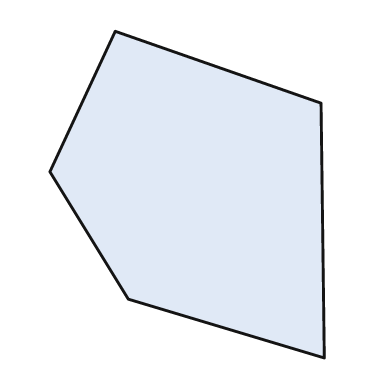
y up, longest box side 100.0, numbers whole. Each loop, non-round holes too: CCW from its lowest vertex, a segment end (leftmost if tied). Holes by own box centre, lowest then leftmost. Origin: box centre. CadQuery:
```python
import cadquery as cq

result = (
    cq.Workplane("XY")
    .moveTo(42.0, -50.0)
    .lineTo(41.0, 28.0)
    .lineTo(-22.0, 50.0)
    .lineTo(-42.0, 7.0)
    .lineTo(-18.0, -32.0)
    .close()
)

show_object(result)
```